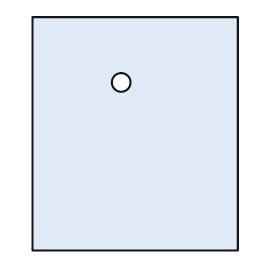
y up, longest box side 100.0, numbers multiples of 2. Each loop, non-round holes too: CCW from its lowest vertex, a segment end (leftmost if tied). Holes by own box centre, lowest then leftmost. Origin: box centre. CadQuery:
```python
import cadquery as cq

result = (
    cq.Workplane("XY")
    .moveTo(-44.0, -50.0)
    .lineTo(44.0, -50.0)
    .lineTo(44.0, 50.0)
    .lineTo(-44.0, 50.0)
    .close()
    .moveTo(-6.0, 22.0)
    .circle(4.0)
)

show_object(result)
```